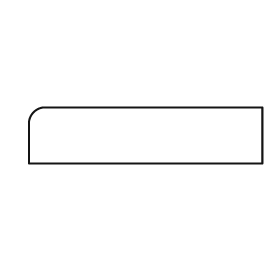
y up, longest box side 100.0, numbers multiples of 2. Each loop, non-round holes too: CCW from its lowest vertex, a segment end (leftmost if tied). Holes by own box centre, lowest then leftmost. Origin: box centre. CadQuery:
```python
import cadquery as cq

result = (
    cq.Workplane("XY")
    .moveTo(-50.0, -12.0)
    .lineTo(50.0, -12.0)
    .lineTo(50.0, 12.0)
    .lineTo(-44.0, 12.0)
    .threePointArc((-48.0, 10.0), (-50.0, 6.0))
    .close()
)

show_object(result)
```